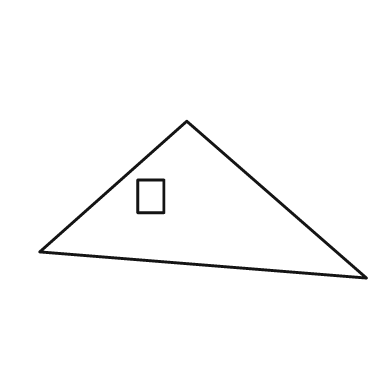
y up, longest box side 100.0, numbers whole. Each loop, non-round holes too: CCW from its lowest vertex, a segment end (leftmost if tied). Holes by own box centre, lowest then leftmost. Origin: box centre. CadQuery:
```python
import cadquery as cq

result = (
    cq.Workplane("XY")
    .moveTo(50.0, -24.0)
    .lineTo(-5.0, 24.0)
    .lineTo(-50.0, -16.0)
    .close()
    .moveTo(-20.0, -4.0)
    .lineTo(-12.0, -4.0)
    .lineTo(-12.0, 6.0)
    .lineTo(-20.0, 6.0)
    .close()
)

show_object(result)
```